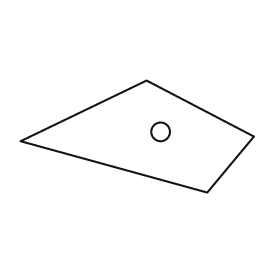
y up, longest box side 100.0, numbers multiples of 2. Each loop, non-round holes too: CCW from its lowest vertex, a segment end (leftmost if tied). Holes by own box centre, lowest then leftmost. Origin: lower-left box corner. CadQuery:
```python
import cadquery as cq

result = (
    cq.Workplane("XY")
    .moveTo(80.0, 0.0)
    .lineTo(100.0, 24.0)
    .lineTo(54.0, 48.0)
    .lineTo(0.0, 22.0)
    .close()
    .moveTo(60.0, 26.0)
    .circle(4.0)
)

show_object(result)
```